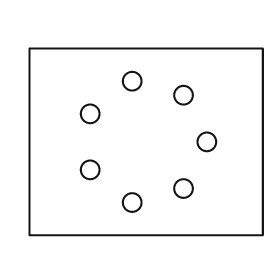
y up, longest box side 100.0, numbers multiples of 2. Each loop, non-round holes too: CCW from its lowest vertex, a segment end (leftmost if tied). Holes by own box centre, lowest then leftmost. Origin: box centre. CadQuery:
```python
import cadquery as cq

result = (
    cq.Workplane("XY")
    .moveTo(-50.0, -40.0)
    .lineTo(50.0, -40.0)
    .lineTo(50.0, 40.0)
    .lineTo(-50.0, 40.0)
    .close()
    .moveTo(-6.0, -26.0)
    .circle(4.0)
    .moveTo(16.0, -20.0)
    .circle(4.0)
    .moveTo(-24.0, -12.0)
    .circle(4.0)
    .moveTo(26.0, 0.0)
    .circle(4.0)
    .moveTo(-24.0, 12.0)
    .circle(4.0)
    .moveTo(16.0, 20.0)
    .circle(4.0)
    .moveTo(-6.0, 26.0)
    .circle(4.0)
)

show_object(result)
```